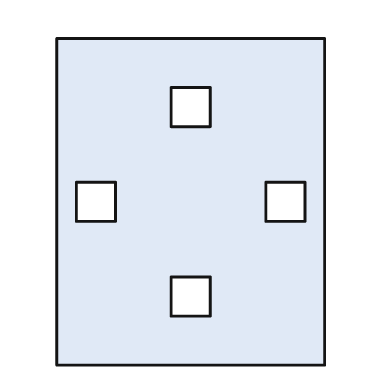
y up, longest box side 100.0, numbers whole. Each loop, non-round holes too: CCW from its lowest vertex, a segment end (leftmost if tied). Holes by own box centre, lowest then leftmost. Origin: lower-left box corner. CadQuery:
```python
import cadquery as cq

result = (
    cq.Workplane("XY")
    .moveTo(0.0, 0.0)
    .lineTo(82.0, 0.0)
    .lineTo(82.0, 100.0)
    .lineTo(0.0, 100.0)
    .close()
    .moveTo(35.0, 15.0)
    .lineTo(47.0, 15.0)
    .lineTo(47.0, 27.0)
    .lineTo(35.0, 27.0)
    .close()
    .moveTo(6.0, 44.0)
    .lineTo(18.0, 44.0)
    .lineTo(18.0, 56.0)
    .lineTo(6.0, 56.0)
    .close()
    .moveTo(64.0, 44.0)
    .lineTo(76.0, 44.0)
    .lineTo(76.0, 56.0)
    .lineTo(64.0, 56.0)
    .close()
    .moveTo(35.0, 73.0)
    .lineTo(47.0, 73.0)
    .lineTo(47.0, 85.0)
    .lineTo(35.0, 85.0)
    .close()
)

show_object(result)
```